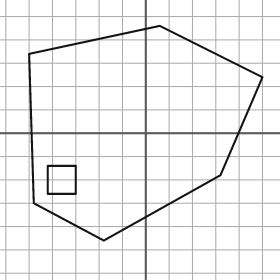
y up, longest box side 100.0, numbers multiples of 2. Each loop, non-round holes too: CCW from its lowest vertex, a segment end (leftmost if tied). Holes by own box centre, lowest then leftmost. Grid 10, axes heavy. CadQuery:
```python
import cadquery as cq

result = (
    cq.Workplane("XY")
    .moveTo(-18.0, -46.0)
    .lineTo(32.0, -18.0)
    .lineTo(50.0, 24.0)
    .lineTo(6.0, 46.0)
    .lineTo(-50.0, 34.0)
    .lineTo(-48.0, -30.0)
    .close()
    .moveTo(-42.0, -26.0)
    .lineTo(-30.0, -26.0)
    .lineTo(-30.0, -14.0)
    .lineTo(-42.0, -14.0)
    .close()
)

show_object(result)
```